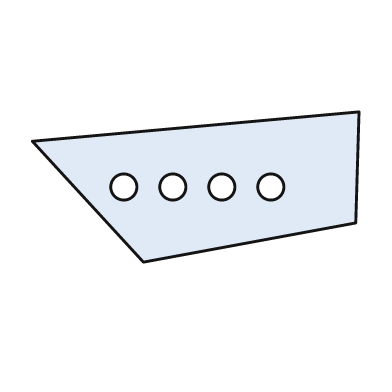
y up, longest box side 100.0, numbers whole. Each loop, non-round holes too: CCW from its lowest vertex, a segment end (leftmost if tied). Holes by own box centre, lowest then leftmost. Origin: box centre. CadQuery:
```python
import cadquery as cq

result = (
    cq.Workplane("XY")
    .moveTo(-16.0, -23.0)
    .lineTo(49.0, -11.0)
    .lineTo(50.0, 23.0)
    .lineTo(-50.0, 14.0)
    .close()
    .moveTo(-22.0, 0.0)
    .circle(4.0)
    .moveTo(-7.0, 0.0)
    .circle(4.0)
    .moveTo(8.0, 0.0)
    .circle(4.0)
    .moveTo(23.0, 0.0)
    .circle(4.0)
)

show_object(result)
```